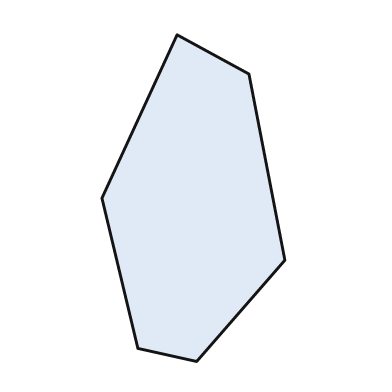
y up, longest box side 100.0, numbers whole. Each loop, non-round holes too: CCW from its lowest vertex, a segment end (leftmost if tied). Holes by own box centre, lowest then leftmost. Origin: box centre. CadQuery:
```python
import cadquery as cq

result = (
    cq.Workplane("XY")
    .moveTo(1.0, -50.0)
    .lineTo(28.0, -19.0)
    .lineTo(17.0, 38.0)
    .lineTo(-5.0, 50.0)
    .lineTo(-28.0, 0.0)
    .lineTo(-17.0, -46.0)
    .close()
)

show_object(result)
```